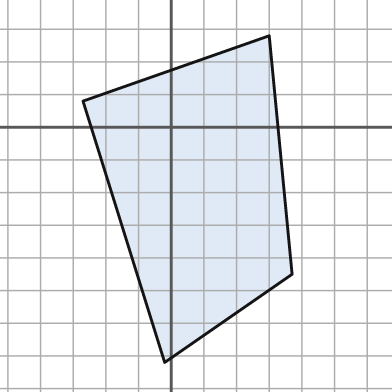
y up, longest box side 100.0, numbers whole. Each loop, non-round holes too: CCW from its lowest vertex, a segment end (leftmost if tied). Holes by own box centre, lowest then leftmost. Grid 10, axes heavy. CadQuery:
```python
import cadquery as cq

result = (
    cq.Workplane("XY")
    .moveTo(-2.0, -72.0)
    .lineTo(37.0, -45.0)
    .lineTo(30.0, 28.0)
    .lineTo(-27.0, 8.0)
    .close()
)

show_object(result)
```